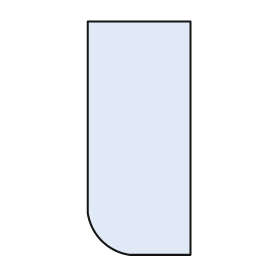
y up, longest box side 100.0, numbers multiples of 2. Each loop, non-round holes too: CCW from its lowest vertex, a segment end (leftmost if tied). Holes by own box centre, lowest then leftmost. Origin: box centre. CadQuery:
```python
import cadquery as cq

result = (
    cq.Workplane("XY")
    .moveTo(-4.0, -50.0)
    .lineTo(22.0, -50.0)
    .lineTo(22.0, 50.0)
    .lineTo(-22.0, 50.0)
    .lineTo(-22.0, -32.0)
    .threePointArc((-16.0, -44.0), (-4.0, -50.0))
    .close()
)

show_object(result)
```